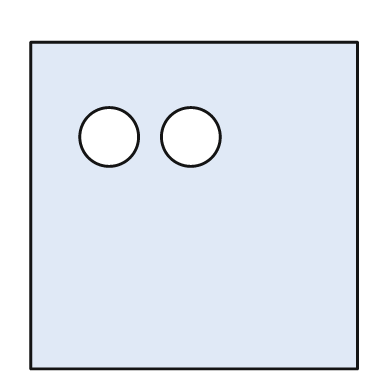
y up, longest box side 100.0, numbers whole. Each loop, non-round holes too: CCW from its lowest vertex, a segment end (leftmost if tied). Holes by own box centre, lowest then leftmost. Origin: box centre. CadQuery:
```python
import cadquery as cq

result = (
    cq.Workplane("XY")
    .moveTo(-50.0, -50.0)
    .lineTo(50.0, -50.0)
    .lineTo(50.0, 50.0)
    .lineTo(-50.0, 50.0)
    .close()
    .moveTo(-26.0, 21.0)
    .circle(9.0)
    .moveTo(-1.0, 21.0)
    .circle(9.0)
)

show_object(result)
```